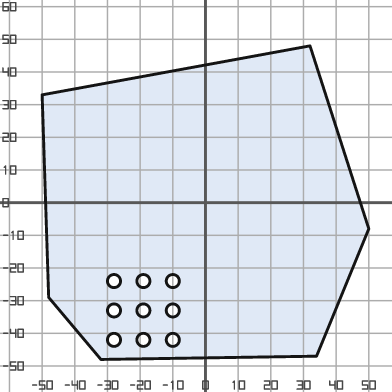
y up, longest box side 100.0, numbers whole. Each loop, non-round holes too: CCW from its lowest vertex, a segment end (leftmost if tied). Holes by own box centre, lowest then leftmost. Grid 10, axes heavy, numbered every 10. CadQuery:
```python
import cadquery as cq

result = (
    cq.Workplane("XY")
    .moveTo(-32.0, -48.0)
    .lineTo(34.0, -47.0)
    .lineTo(50.0, -8.0)
    .lineTo(32.0, 48.0)
    .lineTo(-50.0, 33.0)
    .lineTo(-48.0, -29.0)
    .close()
    .moveTo(-28.0, -42.0)
    .circle(2.0)
    .moveTo(-19.0, -42.0)
    .circle(2.0)
    .moveTo(-10.0, -42.0)
    .circle(2.0)
    .moveTo(-28.0, -33.0)
    .circle(2.0)
    .moveTo(-19.0, -33.0)
    .circle(2.0)
    .moveTo(-10.0, -33.0)
    .circle(2.0)
    .moveTo(-28.0, -24.0)
    .circle(2.0)
    .moveTo(-19.0, -24.0)
    .circle(2.0)
    .moveTo(-10.0, -24.0)
    .circle(2.0)
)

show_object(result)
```